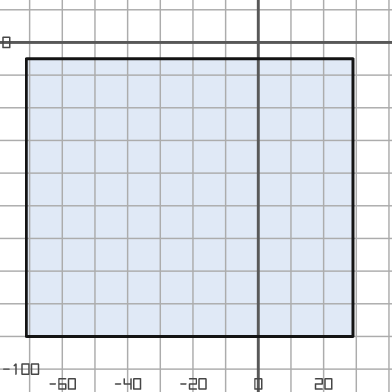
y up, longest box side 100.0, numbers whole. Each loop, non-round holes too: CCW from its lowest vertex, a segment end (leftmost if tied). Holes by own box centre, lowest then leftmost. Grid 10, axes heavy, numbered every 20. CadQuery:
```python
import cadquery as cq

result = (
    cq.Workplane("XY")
    .moveTo(-71.0, -90.0)
    .lineTo(29.0, -90.0)
    .lineTo(29.0, -5.0)
    .lineTo(-71.0, -5.0)
    .close()
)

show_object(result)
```